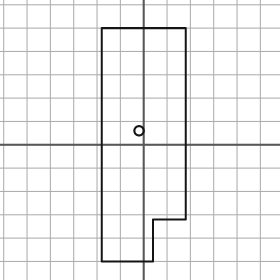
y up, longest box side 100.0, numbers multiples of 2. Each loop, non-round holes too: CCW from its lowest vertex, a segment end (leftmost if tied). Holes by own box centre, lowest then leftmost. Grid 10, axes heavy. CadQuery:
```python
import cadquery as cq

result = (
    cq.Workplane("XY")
    .moveTo(-18.0, -50.0)
    .lineTo(4.0, -50.0)
    .lineTo(4.0, -32.0)
    .lineTo(18.0, -32.0)
    .lineTo(18.0, 50.0)
    .lineTo(-18.0, 50.0)
    .close()
    .moveTo(-2.0, 6.0)
    .circle(2.0)
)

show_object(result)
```